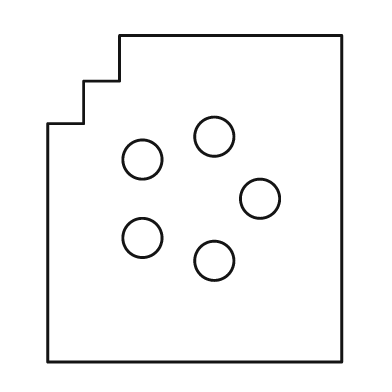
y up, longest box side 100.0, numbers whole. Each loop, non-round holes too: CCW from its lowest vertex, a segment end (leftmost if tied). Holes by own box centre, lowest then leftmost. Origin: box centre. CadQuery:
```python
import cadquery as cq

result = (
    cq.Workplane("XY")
    .moveTo(-45.0, -50.0)
    .lineTo(45.0, -50.0)
    .lineTo(45.0, 50.0)
    .lineTo(-23.0, 50.0)
    .lineTo(-23.0, 36.0)
    .lineTo(-34.0, 36.0)
    .lineTo(-34.0, 23.0)
    .lineTo(-45.0, 23.0)
    .close()
    .moveTo(6.0, -19.0)
    .circle(6.0)
    .moveTo(-16.0, -12.0)
    .circle(6.0)
    .moveTo(20.0, 0.0)
    .circle(6.0)
    .moveTo(-16.0, 12.0)
    .circle(6.0)
    .moveTo(6.0, 19.0)
    .circle(6.0)
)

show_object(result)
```